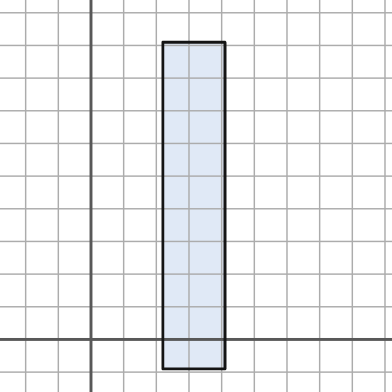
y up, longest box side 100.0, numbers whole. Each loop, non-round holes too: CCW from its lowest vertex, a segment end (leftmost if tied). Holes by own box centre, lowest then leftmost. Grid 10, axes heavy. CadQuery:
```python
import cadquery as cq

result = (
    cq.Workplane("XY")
    .moveTo(22.0, -9.0)
    .lineTo(41.0, -9.0)
    .lineTo(41.0, 91.0)
    .lineTo(22.0, 91.0)
    .close()
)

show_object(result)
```